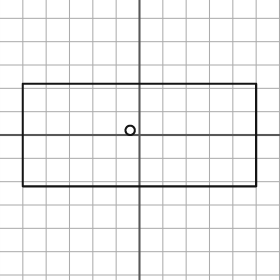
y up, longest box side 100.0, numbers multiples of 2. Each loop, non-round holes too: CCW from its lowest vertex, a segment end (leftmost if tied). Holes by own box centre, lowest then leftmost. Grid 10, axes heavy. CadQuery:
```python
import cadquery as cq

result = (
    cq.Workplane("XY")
    .moveTo(-50.0, -22.0)
    .lineTo(50.0, -22.0)
    .lineTo(50.0, 22.0)
    .lineTo(-50.0, 22.0)
    .close()
    .moveTo(-4.0, 2.0)
    .circle(2.0)
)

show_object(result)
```